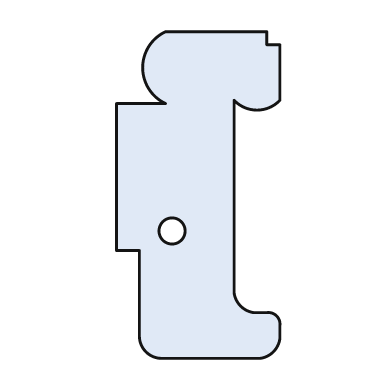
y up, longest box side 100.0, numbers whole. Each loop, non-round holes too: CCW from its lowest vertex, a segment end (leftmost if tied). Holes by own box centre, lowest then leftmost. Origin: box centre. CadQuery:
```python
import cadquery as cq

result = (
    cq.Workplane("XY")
    .moveTo(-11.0, -50.0)
    .lineTo(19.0, -50.0)
    .threePointArc((23.0, -48.0), (25.0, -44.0))
    .lineTo(25.0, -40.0)
    .threePointArc((24.0, -37.0), (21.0, -36.0))
    .lineTo(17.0, -36.0)
    .threePointArc((13.0, -34.0), (11.0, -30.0))
    .lineTo(11.0, 29.0)
    .threePointArc((18.0, 26.0), (25.0, 29.0))
    .lineTo(25.0, 46.0)
    .lineTo(21.0, 46.0)
    .lineTo(21.0, 50.0)
    .lineTo(-10.0, 50.0)
    .threePointArc((-17.0, 39.0), (-10.0, 28.0))
    .lineTo(-25.0, 28.0)
    .lineTo(-25.0, -17.0)
    .lineTo(-18.0, -17.0)
    .lineTo(-18.0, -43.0)
    .threePointArc((-16.0, -48.0), (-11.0, -50.0))
    .close()
    .moveTo(-8.0, -11.0)
    .circle(4.0)
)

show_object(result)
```